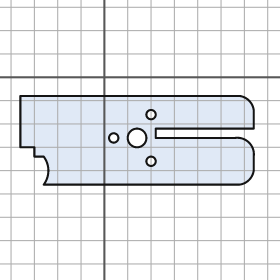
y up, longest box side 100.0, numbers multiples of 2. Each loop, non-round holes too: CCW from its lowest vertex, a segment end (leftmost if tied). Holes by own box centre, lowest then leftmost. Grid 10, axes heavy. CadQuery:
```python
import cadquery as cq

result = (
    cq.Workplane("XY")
    .moveTo(-26.0, -46.0)
    .lineTo(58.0, -46.0)
    .threePointArc((62.0, -44.0), (64.0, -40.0))
    .lineTo(64.0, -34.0)
    .threePointArc((62.0, -28.0), (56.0, -26.0))
    .lineTo(22.0, -26.0)
    .lineTo(22.0, -22.0)
    .lineTo(64.0, -22.0)
    .lineTo(64.0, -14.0)
    .threePointArc((62.0, -10.0), (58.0, -8.0))
    .lineTo(-36.0, -8.0)
    .lineTo(-36.0, -30.0)
    .lineTo(-30.0, -30.0)
    .lineTo(-30.0, -34.0)
    .lineTo(-26.0, -34.0)
    .threePointArc((-24.0, -40.0), (-26.0, -46.0))
    .close()
    .moveTo(20.0, -36.0)
    .circle(2.0)
    .moveTo(4.0, -26.0)
    .circle(2.0)
    .moveTo(14.0, -26.0)
    .circle(4.0)
    .moveTo(20.0, -16.0)
    .circle(2.0)
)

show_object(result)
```